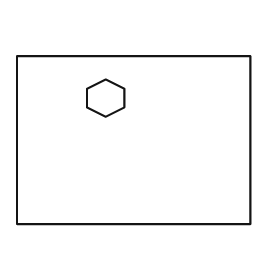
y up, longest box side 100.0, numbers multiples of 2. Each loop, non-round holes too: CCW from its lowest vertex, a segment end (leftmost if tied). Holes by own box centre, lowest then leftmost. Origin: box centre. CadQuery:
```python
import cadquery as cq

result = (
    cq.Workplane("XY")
    .moveTo(-50.0, -36.0)
    .lineTo(50.0, -36.0)
    .lineTo(50.0, 36.0)
    .lineTo(-50.0, 36.0)
    .close()
    .moveTo(-12.0, 10.0)
    .lineTo(-4.0, 14.0)
    .lineTo(-4.0, 22.0)
    .lineTo(-12.0, 26.0)
    .lineTo(-20.0, 22.0)
    .lineTo(-20.0, 14.0)
    .close()
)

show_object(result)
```